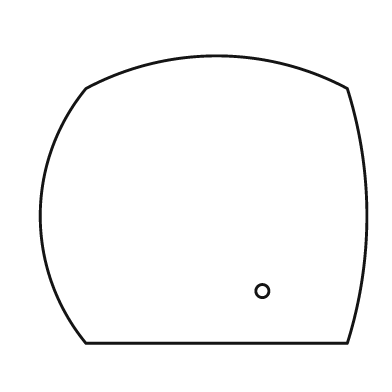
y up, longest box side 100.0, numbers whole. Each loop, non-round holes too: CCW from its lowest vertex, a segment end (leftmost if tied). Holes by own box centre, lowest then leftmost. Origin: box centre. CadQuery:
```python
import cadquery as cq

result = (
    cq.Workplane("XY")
    .moveTo(-36.0, -44.0)
    .lineTo(44.0, -44.0)
    .threePointArc((50.0, -5.0), (44.0, 34.0))
    .threePointArc((4.0, 44.0), (-36.0, 34.0))
    .threePointArc((-50.0, -5.0), (-36.0, -44.0))
    .close()
    .moveTo(18.0, -28.0)
    .circle(2.0)
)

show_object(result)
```